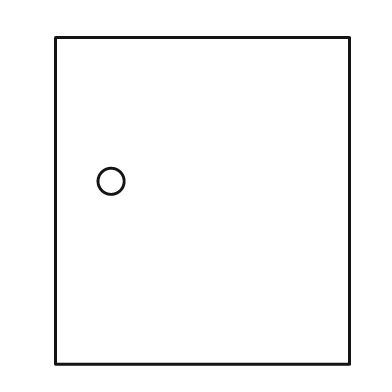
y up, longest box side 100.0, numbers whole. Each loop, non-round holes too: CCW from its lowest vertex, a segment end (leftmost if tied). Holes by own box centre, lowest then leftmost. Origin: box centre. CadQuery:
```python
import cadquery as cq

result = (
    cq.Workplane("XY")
    .moveTo(-45.0, -50.0)
    .lineTo(45.0, -50.0)
    .lineTo(45.0, 50.0)
    .lineTo(-45.0, 50.0)
    .close()
    .moveTo(-28.0, 6.0)
    .circle(4.0)
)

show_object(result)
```